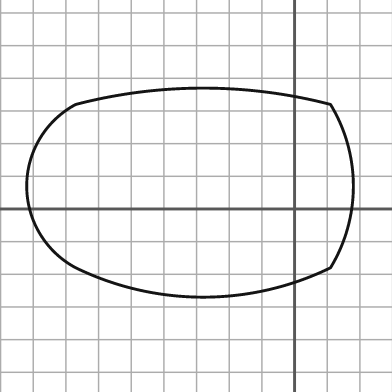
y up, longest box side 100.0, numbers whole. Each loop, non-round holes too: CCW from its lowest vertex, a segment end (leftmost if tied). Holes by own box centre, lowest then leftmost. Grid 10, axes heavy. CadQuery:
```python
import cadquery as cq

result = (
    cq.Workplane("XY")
    .moveTo(-67.0, -18.0)
    .threePointArc((-28.0, -27.0), (11.0, -18.0))
    .threePointArc((18.0, 7.0), (11.0, 32.0))
    .threePointArc((-28.0, 37.0), (-67.0, 32.0))
    .threePointArc((-82.0, 7.0), (-67.0, -18.0))
    .close()
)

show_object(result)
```